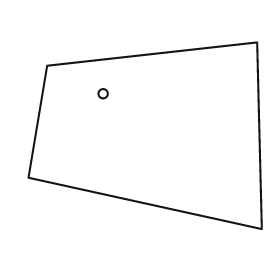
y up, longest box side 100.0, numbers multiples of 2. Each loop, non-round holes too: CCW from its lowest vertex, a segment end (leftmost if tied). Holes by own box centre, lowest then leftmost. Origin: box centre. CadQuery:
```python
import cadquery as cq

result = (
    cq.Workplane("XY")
    .moveTo(50.0, -40.0)
    .lineTo(48.0, 40.0)
    .lineTo(-42.0, 30.0)
    .lineTo(-50.0, -18.0)
    .close()
    .moveTo(-18.0, 18.0)
    .circle(2.0)
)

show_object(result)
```